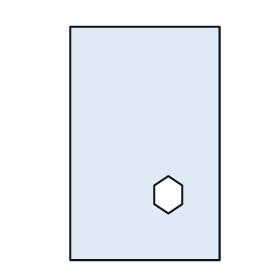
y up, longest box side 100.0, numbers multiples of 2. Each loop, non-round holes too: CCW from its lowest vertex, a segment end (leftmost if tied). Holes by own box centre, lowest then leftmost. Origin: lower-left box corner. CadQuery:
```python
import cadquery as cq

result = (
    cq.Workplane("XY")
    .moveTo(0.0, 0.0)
    .lineTo(64.0, 0.0)
    .lineTo(64.0, 100.0)
    .lineTo(0.0, 100.0)
    .close()
    .moveTo(42.0, 20.0)
    .lineTo(48.0, 24.0)
    .lineTo(48.0, 32.0)
    .lineTo(42.0, 36.0)
    .lineTo(36.0, 32.0)
    .lineTo(36.0, 24.0)
    .close()
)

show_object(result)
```